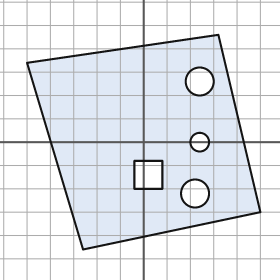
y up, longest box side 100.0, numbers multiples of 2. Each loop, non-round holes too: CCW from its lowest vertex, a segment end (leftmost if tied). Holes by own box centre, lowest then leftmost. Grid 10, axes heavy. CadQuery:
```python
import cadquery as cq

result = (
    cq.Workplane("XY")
    .moveTo(-26.0, -46.0)
    .lineTo(50.0, -30.0)
    .lineTo(32.0, 46.0)
    .lineTo(-50.0, 34.0)
    .close()
    .moveTo(22.0, -22.0)
    .circle(6.0)
    .moveTo(-4.0, -20.0)
    .lineTo(8.0, -20.0)
    .lineTo(8.0, -8.0)
    .lineTo(-4.0, -8.0)
    .close()
    .moveTo(24.0, 0.0)
    .circle(4.0)
    .moveTo(24.0, 26.0)
    .circle(6.0)
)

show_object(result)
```